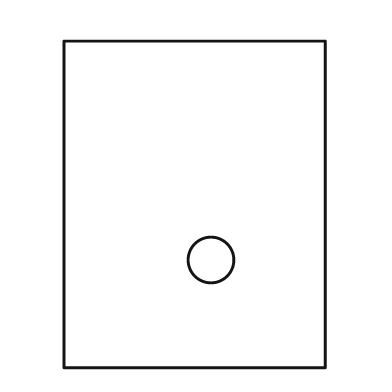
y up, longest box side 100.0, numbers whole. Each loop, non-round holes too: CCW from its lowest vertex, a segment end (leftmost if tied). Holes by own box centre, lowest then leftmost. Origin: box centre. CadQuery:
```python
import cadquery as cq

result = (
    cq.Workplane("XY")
    .moveTo(-40.0, -50.0)
    .lineTo(40.0, -50.0)
    .lineTo(40.0, 50.0)
    .lineTo(-40.0, 50.0)
    .close()
    .moveTo(5.0, -17.0)
    .circle(7.0)
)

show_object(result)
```